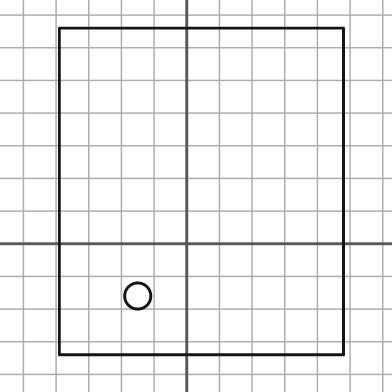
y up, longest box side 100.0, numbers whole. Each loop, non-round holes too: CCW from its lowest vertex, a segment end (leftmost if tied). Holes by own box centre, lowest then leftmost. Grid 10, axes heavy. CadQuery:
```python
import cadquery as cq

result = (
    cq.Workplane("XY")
    .moveTo(-39.0, -34.0)
    .lineTo(48.0, -34.0)
    .lineTo(48.0, 66.0)
    .lineTo(-39.0, 66.0)
    .close()
    .moveTo(-15.0, -16.0)
    .circle(4.0)
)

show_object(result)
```